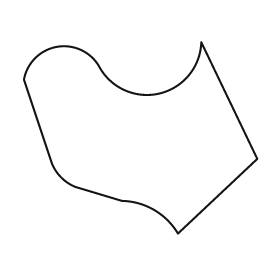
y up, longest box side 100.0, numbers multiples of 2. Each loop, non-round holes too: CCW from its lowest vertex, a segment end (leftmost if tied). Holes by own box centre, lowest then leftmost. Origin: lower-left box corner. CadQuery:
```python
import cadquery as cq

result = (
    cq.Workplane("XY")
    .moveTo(66.0, 0.0)
    .lineTo(100.0, 32.0)
    .lineTo(76.0, 82.0)
    .threePointArc((58.0, 60.0), (32.0, 72.0))
    .threePointArc((14.0, 80.0), (0.0, 66.0))
    .lineTo(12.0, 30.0)
    .threePointArc((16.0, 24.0), (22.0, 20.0))
    .lineTo(42.0, 14.0)
    .threePointArc((56.0, 10.0), (66.0, 0.0))
    .close()
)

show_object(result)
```